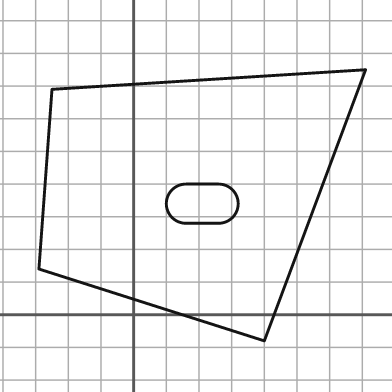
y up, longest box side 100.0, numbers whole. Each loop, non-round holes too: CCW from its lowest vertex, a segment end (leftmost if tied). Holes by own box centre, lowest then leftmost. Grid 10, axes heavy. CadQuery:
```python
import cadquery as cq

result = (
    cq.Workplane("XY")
    .moveTo(40.0, -8.0)
    .lineTo(71.0, 75.0)
    .lineTo(-25.0, 69.0)
    .lineTo(-29.0, 14.0)
    .close()
    .moveTo(16.0, 28.0)
    .lineTo(26.0, 28.0)
    .threePointArc((32.0, 34.0), (26.0, 40.0))
    .lineTo(16.0, 40.0)
    .threePointArc((10.0, 34.0), (16.0, 28.0))
    .close()
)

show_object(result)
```